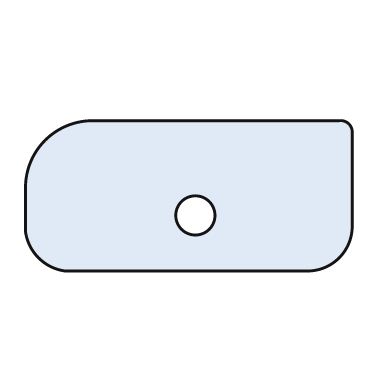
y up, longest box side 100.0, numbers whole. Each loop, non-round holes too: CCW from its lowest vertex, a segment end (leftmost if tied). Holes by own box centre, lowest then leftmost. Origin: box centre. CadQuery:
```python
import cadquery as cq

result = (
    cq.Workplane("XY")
    .moveTo(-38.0, -23.0)
    .lineTo(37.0, -23.0)
    .threePointArc((46.0, -19.0), (50.0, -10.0))
    .lineTo(50.0, 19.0)
    .threePointArc((49.0, 22.0), (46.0, 23.0))
    .lineTo(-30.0, 23.0)
    .threePointArc((-44.0, 17.0), (-50.0, 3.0))
    .lineTo(-50.0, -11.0)
    .threePointArc((-46.0, -19.0), (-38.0, -23.0))
    .close()
    .moveTo(2.0, -6.0)
    .circle(6.0)
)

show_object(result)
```